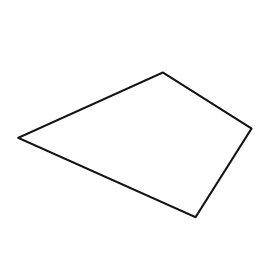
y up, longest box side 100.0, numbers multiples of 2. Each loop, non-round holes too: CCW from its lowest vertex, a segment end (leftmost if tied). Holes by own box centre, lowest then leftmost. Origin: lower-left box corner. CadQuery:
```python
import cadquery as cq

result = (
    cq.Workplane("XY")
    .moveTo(76.0, 0.0)
    .lineTo(100.0, 38.0)
    .lineTo(62.0, 62.0)
    .lineTo(0.0, 34.0)
    .close()
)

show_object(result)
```